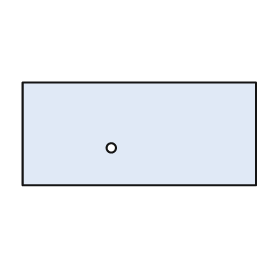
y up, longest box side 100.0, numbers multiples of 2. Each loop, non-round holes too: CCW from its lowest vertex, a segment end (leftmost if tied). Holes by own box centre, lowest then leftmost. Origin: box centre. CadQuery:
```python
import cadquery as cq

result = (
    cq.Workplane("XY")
    .moveTo(-50.0, -22.0)
    .lineTo(50.0, -22.0)
    .lineTo(50.0, 22.0)
    .lineTo(-50.0, 22.0)
    .close()
    .moveTo(-12.0, -6.0)
    .circle(2.0)
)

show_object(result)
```